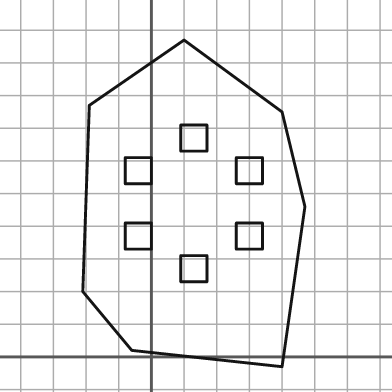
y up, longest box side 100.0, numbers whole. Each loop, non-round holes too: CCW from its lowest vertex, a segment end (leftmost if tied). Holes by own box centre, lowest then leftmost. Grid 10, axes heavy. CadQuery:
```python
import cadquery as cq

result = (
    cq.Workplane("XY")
    .moveTo(40.0, -3.0)
    .lineTo(47.0, 46.0)
    .lineTo(40.0, 75.0)
    .lineTo(10.0, 97.0)
    .lineTo(-19.0, 77.0)
    .lineTo(-21.0, 20.0)
    .lineTo(-6.0, 2.0)
    .close()
    .moveTo(9.0, 23.0)
    .lineTo(17.0, 23.0)
    .lineTo(17.0, 31.0)
    .lineTo(9.0, 31.0)
    .close()
    .moveTo(-8.0, 33.0)
    .lineTo(0.0, 33.0)
    .lineTo(0.0, 41.0)
    .lineTo(-8.0, 41.0)
    .close()
    .moveTo(26.0, 33.0)
    .lineTo(34.0, 33.0)
    .lineTo(34.0, 41.0)
    .lineTo(26.0, 41.0)
    .close()
    .moveTo(-8.0, 53.0)
    .lineTo(0.0, 53.0)
    .lineTo(0.0, 61.0)
    .lineTo(-8.0, 61.0)
    .close()
    .moveTo(26.0, 53.0)
    .lineTo(34.0, 53.0)
    .lineTo(34.0, 61.0)
    .lineTo(26.0, 61.0)
    .close()
    .moveTo(9.0, 63.0)
    .lineTo(17.0, 63.0)
    .lineTo(17.0, 71.0)
    .lineTo(9.0, 71.0)
    .close()
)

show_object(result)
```